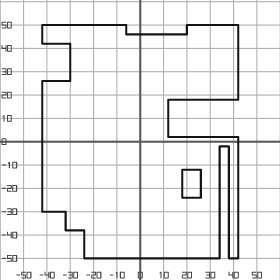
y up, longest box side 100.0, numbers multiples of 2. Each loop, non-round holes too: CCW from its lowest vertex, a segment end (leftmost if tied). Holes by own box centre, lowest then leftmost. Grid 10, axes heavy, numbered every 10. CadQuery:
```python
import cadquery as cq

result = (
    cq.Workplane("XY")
    .moveTo(-24.0, -50.0)
    .lineTo(34.0, -50.0)
    .lineTo(34.0, -2.0)
    .lineTo(38.0, -2.0)
    .lineTo(38.0, -50.0)
    .lineTo(42.0, -50.0)
    .lineTo(42.0, 2.0)
    .lineTo(12.0, 2.0)
    .lineTo(12.0, 18.0)
    .lineTo(42.0, 18.0)
    .lineTo(42.0, 50.0)
    .lineTo(20.0, 50.0)
    .lineTo(20.0, 46.0)
    .lineTo(-6.0, 46.0)
    .lineTo(-6.0, 50.0)
    .lineTo(-42.0, 50.0)
    .lineTo(-42.0, 42.0)
    .lineTo(-30.0, 42.0)
    .lineTo(-30.0, 26.0)
    .lineTo(-42.0, 26.0)
    .lineTo(-42.0, -30.0)
    .lineTo(-32.0, -30.0)
    .lineTo(-32.0, -38.0)
    .lineTo(-24.0, -38.0)
    .close()
    .moveTo(18.0, -24.0)
    .lineTo(26.0, -24.0)
    .lineTo(26.0, -12.0)
    .lineTo(18.0, -12.0)
    .close()
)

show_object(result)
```